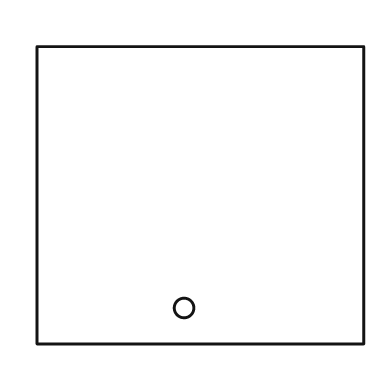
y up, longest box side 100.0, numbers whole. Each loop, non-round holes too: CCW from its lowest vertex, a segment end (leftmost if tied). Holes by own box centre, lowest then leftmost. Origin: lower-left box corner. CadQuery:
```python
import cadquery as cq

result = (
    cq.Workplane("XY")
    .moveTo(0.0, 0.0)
    .lineTo(100.0, 0.0)
    .lineTo(100.0, 91.0)
    .lineTo(0.0, 91.0)
    .close()
    .moveTo(45.0, 11.0)
    .circle(3.0)
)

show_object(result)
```